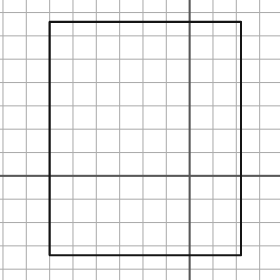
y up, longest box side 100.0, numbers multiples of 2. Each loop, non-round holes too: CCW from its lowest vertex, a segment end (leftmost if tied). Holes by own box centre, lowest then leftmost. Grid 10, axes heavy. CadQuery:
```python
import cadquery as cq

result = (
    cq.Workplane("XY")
    .moveTo(-60.0, -34.0)
    .lineTo(22.0, -34.0)
    .lineTo(22.0, 66.0)
    .lineTo(-60.0, 66.0)
    .close()
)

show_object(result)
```